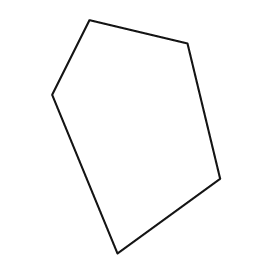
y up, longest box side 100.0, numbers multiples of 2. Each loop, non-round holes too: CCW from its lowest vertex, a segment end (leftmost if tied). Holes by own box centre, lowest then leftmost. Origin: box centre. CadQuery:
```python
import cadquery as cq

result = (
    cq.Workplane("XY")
    .moveTo(-8.0, -50.0)
    .lineTo(36.0, -18.0)
    .lineTo(22.0, 40.0)
    .lineTo(-20.0, 50.0)
    .lineTo(-36.0, 18.0)
    .close()
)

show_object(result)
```